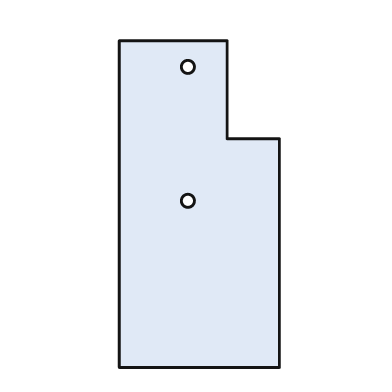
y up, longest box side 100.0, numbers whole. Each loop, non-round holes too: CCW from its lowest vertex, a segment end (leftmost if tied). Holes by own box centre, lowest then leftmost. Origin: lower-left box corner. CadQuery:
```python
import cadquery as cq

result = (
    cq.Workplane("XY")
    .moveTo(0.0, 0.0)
    .lineTo(49.0, 0.0)
    .lineTo(49.0, 70.0)
    .lineTo(33.0, 70.0)
    .lineTo(33.0, 100.0)
    .lineTo(0.0, 100.0)
    .close()
    .moveTo(21.0, 51.0)
    .circle(2.0)
    .moveTo(21.0, 92.0)
    .circle(2.0)
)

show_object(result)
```